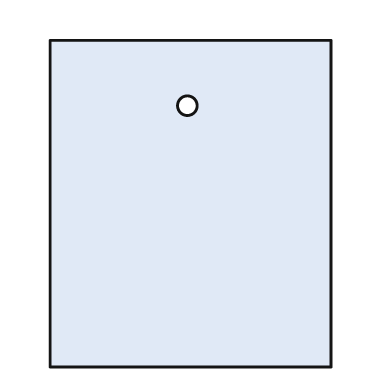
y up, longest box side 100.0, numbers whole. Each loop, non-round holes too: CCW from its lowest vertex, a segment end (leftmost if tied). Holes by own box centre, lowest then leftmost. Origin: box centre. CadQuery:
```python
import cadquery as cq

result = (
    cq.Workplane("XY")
    .moveTo(-43.0, -50.0)
    .lineTo(43.0, -50.0)
    .lineTo(43.0, 50.0)
    .lineTo(-43.0, 50.0)
    .close()
    .moveTo(-1.0, 30.0)
    .circle(3.0)
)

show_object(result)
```